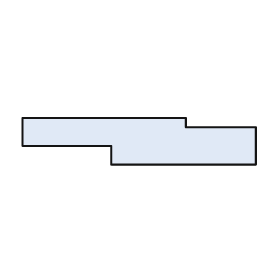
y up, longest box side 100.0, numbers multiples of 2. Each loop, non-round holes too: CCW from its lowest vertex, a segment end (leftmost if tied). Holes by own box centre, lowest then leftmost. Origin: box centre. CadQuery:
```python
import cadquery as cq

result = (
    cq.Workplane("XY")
    .moveTo(-12.0, -10.0)
    .lineTo(50.0, -10.0)
    .lineTo(50.0, 6.0)
    .lineTo(20.0, 6.0)
    .lineTo(20.0, 10.0)
    .lineTo(-50.0, 10.0)
    .lineTo(-50.0, -2.0)
    .lineTo(-12.0, -2.0)
    .close()
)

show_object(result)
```